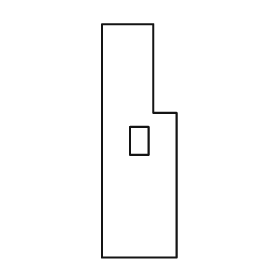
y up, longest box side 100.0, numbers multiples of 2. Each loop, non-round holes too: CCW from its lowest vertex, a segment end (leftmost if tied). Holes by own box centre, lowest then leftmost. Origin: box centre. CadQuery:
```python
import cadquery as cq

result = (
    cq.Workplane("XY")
    .moveTo(-16.0, -50.0)
    .lineTo(16.0, -50.0)
    .lineTo(16.0, 12.0)
    .lineTo(6.0, 12.0)
    .lineTo(6.0, 50.0)
    .lineTo(-16.0, 50.0)
    .close()
    .moveTo(-4.0, -6.0)
    .lineTo(4.0, -6.0)
    .lineTo(4.0, 6.0)
    .lineTo(-4.0, 6.0)
    .close()
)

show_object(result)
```